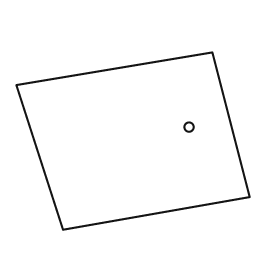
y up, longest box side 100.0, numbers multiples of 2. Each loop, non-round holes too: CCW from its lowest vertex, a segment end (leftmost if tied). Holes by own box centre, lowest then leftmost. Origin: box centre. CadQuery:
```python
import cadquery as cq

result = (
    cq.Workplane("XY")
    .moveTo(-30.0, -38.0)
    .lineTo(50.0, -24.0)
    .lineTo(34.0, 38.0)
    .lineTo(-50.0, 24.0)
    .close()
    .moveTo(24.0, 6.0)
    .circle(2.0)
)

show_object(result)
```